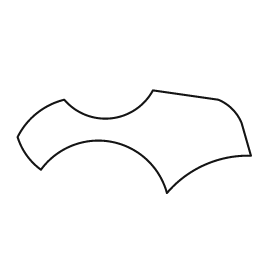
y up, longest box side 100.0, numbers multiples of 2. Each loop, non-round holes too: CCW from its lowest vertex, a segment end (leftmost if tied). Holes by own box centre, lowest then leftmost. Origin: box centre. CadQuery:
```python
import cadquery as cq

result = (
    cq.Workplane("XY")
    .moveTo(14.0, -22.0)
    .threePointArc((30.0, -10.0), (50.0, -6.0))
    .lineTo(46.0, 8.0)
    .threePointArc((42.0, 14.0), (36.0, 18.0))
    .lineTo(8.0, 22.0)
    .threePointArc((-10.0, 10.0), (-30.0, 18.0))
    .threePointArc((-42.0, 12.0), (-50.0, 2.0))
    .threePointArc((-46.0, -6.0), (-40.0, -12.0))
    .threePointArc((-10.0, 0.0), (14.0, -22.0))
    .close()
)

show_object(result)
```